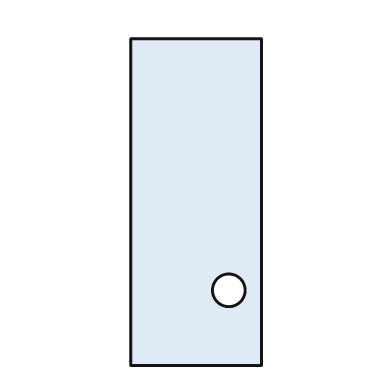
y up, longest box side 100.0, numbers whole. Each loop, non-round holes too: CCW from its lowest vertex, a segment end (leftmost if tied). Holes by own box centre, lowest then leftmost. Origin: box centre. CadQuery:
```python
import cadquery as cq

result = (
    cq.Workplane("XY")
    .moveTo(-20.0, -50.0)
    .lineTo(20.0, -50.0)
    .lineTo(20.0, 50.0)
    .lineTo(-20.0, 50.0)
    .close()
    .moveTo(10.0, -27.0)
    .circle(5.0)
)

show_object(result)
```